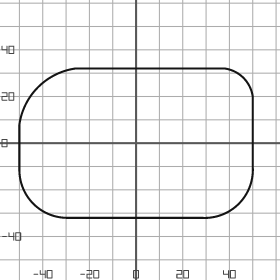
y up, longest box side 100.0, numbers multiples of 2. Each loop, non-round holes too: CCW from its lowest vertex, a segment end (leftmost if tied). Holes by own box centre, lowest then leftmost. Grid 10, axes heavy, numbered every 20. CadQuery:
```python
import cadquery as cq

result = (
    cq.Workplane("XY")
    .moveTo(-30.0, -32.0)
    .lineTo(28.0, -32.0)
    .threePointArc((44.0, -26.0), (50.0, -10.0))
    .lineTo(50.0, 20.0)
    .threePointArc((46.0, 28.0), (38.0, 32.0))
    .lineTo(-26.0, 32.0)
    .threePointArc((-42.0, 24.0), (-50.0, 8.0))
    .lineTo(-50.0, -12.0)
    .threePointArc((-44.0, -26.0), (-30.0, -32.0))
    .close()
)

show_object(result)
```